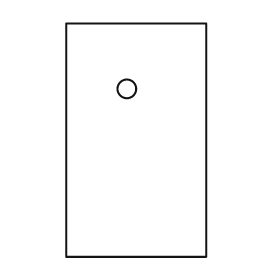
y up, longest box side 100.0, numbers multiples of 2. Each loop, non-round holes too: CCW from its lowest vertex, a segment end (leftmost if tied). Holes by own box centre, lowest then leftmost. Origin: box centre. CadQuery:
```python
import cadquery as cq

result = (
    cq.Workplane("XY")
    .moveTo(-30.0, -50.0)
    .lineTo(30.0, -50.0)
    .lineTo(30.0, 50.0)
    .lineTo(-30.0, 50.0)
    .close()
    .moveTo(-4.0, 22.0)
    .circle(4.0)
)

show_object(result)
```